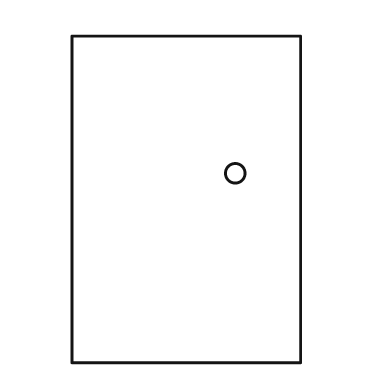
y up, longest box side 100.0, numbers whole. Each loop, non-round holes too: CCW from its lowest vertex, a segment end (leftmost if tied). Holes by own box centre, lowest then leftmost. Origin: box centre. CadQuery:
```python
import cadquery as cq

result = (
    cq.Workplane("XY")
    .moveTo(-35.0, -50.0)
    .lineTo(35.0, -50.0)
    .lineTo(35.0, 50.0)
    .lineTo(-35.0, 50.0)
    .close()
    .moveTo(15.0, 8.0)
    .circle(3.0)
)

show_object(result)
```